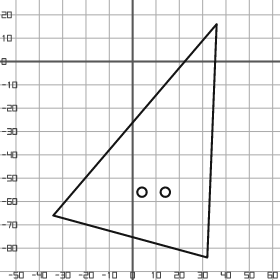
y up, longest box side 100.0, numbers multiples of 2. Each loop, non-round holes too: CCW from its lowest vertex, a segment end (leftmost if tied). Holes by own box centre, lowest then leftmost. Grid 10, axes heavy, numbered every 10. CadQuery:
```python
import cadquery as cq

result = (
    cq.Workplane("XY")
    .moveTo(32.0, -84.0)
    .lineTo(36.0, 16.0)
    .lineTo(-34.0, -66.0)
    .close()
    .moveTo(4.0, -56.0)
    .circle(2.0)
    .moveTo(14.0, -56.0)
    .circle(2.0)
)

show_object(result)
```